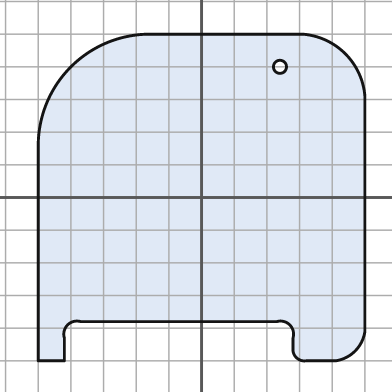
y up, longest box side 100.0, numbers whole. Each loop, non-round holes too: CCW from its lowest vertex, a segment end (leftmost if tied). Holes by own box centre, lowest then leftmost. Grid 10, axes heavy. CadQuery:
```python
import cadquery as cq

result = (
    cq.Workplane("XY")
    .moveTo(-50.0, -50.0)
    .lineTo(-42.0, -50.0)
    .lineTo(-42.0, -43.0)
    .threePointArc((-41.0, -39.0), (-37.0, -38.0))
    .lineTo(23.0, -38.0)
    .threePointArc((27.0, -39.0), (28.0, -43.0))
    .lineTo(28.0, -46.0)
    .threePointArc((29.0, -49.0), (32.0, -50.0))
    .lineTo(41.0, -50.0)
    .threePointArc((47.0, -47.0), (50.0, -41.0))
    .lineTo(50.0, 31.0)
    .threePointArc((44.0, 44.0), (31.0, 50.0))
    .lineTo(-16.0, 50.0)
    .threePointArc((-40.0, 40.0), (-50.0, 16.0))
    .close()
    .moveTo(24.0, 40.0)
    .circle(2.0)
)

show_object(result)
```